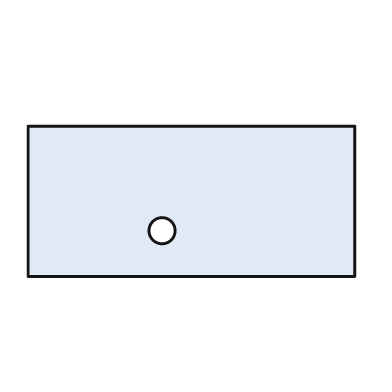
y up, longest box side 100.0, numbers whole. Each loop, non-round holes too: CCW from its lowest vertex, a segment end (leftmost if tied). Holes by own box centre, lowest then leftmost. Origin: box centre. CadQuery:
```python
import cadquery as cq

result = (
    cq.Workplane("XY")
    .moveTo(-50.0, -23.0)
    .lineTo(50.0, -23.0)
    .lineTo(50.0, 23.0)
    .lineTo(-50.0, 23.0)
    .close()
    .moveTo(-9.0, -9.0)
    .circle(4.0)
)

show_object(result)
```